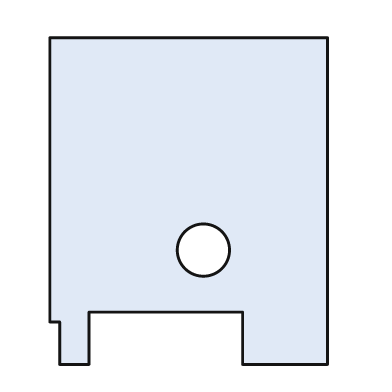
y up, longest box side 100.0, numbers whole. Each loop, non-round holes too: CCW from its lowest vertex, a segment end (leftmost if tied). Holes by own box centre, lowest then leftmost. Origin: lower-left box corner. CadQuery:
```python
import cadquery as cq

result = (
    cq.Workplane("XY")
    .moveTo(3.0, 0.0)
    .lineTo(12.0, 0.0)
    .lineTo(12.0, 16.0)
    .lineTo(59.0, 16.0)
    .lineTo(59.0, 0.0)
    .lineTo(85.0, 0.0)
    .lineTo(85.0, 100.0)
    .lineTo(0.0, 100.0)
    .lineTo(0.0, 13.0)
    .lineTo(3.0, 13.0)
    .close()
    .moveTo(47.0, 35.0)
    .circle(8.0)
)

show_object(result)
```